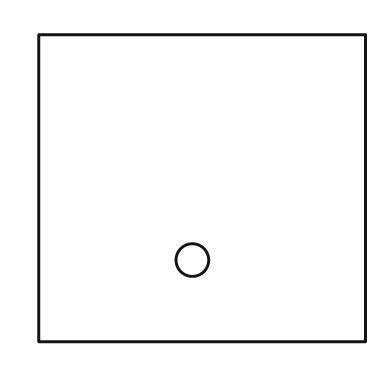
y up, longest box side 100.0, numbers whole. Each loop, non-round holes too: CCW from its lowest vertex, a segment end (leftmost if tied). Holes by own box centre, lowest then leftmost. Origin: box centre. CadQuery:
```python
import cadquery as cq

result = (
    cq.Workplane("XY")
    .moveTo(-50.0, -47.0)
    .lineTo(50.0, -47.0)
    .lineTo(50.0, 47.0)
    .lineTo(-50.0, 47.0)
    .close()
    .moveTo(-3.0, -22.0)
    .circle(5.0)
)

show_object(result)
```